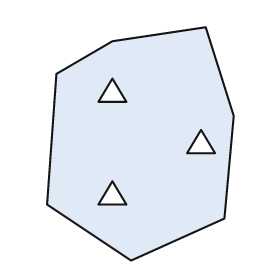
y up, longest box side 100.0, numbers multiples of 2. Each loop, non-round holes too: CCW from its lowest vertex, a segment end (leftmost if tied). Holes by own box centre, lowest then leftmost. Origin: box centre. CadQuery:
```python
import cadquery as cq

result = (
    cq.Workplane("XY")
    .moveTo(-4.0, -50.0)
    .lineTo(36.0, -32.0)
    .lineTo(40.0, 12.0)
    .lineTo(28.0, 50.0)
    .lineTo(-12.0, 44.0)
    .lineTo(-36.0, 30.0)
    .lineTo(-40.0, -26.0)
    .close()
    .moveTo(-18.0, -26.0)
    .lineTo(-6.0, -26.0)
    .lineTo(-12.0, -16.0)
    .close()
    .moveTo(20.0, -4.0)
    .lineTo(32.0, -4.0)
    .lineTo(26.0, 6.0)
    .close()
    .moveTo(-18.0, 18.0)
    .lineTo(-6.0, 18.0)
    .lineTo(-12.0, 28.0)
    .close()
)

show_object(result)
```